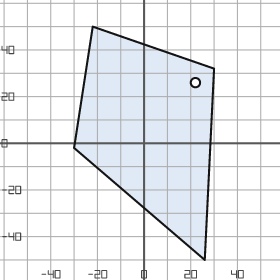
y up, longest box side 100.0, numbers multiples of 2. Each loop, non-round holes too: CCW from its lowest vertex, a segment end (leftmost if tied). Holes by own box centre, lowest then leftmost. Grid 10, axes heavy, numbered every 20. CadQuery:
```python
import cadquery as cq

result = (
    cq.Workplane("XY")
    .moveTo(26.0, -50.0)
    .lineTo(30.0, 32.0)
    .lineTo(-22.0, 50.0)
    .lineTo(-30.0, -2.0)
    .close()
    .moveTo(22.0, 26.0)
    .circle(2.0)
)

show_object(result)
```